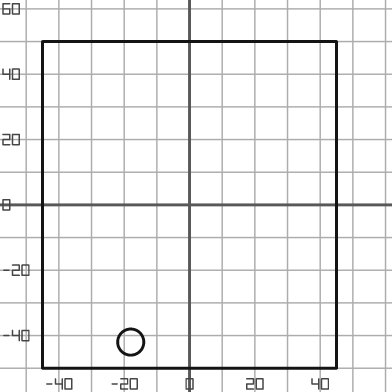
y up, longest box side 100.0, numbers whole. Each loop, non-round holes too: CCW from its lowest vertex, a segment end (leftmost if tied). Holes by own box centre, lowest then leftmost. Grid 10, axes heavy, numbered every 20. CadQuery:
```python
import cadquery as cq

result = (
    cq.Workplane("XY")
    .moveTo(-45.0, -50.0)
    .lineTo(45.0, -50.0)
    .lineTo(45.0, 50.0)
    .lineTo(-45.0, 50.0)
    .close()
    .moveTo(-18.0, -42.0)
    .circle(4.0)
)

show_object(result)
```